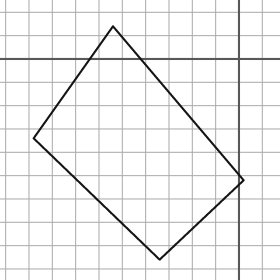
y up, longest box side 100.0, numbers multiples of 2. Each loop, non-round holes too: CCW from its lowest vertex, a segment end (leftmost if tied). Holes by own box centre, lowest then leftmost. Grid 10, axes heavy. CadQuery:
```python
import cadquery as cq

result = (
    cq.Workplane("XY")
    .moveTo(-34.0, -86.0)
    .lineTo(2.0, -52.0)
    .lineTo(-54.0, 14.0)
    .lineTo(-88.0, -34.0)
    .close()
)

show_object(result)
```